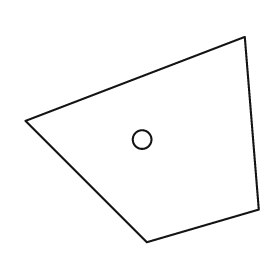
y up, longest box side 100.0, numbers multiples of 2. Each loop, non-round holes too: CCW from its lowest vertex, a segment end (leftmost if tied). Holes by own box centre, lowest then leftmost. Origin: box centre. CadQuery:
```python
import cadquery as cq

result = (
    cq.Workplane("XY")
    .moveTo(2.0, -44.0)
    .lineTo(50.0, -30.0)
    .lineTo(44.0, 44.0)
    .lineTo(-50.0, 8.0)
    .close()
    .moveTo(0.0, 0.0)
    .circle(4.0)
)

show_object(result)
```